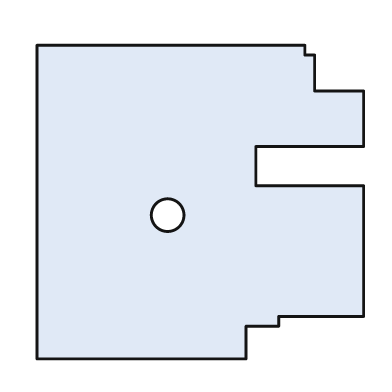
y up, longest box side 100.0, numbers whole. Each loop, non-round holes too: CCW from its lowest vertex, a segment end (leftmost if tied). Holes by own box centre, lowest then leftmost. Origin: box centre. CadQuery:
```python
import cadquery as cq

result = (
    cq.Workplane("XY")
    .moveTo(-50.0, -48.0)
    .lineTo(14.0, -48.0)
    .lineTo(14.0, -38.0)
    .lineTo(24.0, -38.0)
    .lineTo(24.0, -35.0)
    .lineTo(50.0, -35.0)
    .lineTo(50.0, 5.0)
    .lineTo(17.0, 5.0)
    .lineTo(17.0, 17.0)
    .lineTo(50.0, 17.0)
    .lineTo(50.0, 34.0)
    .lineTo(35.0, 34.0)
    .lineTo(35.0, 45.0)
    .lineTo(32.0, 45.0)
    .lineTo(32.0, 48.0)
    .lineTo(-50.0, 48.0)
    .close()
    .moveTo(-10.0, -4.0)
    .circle(5.0)
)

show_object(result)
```